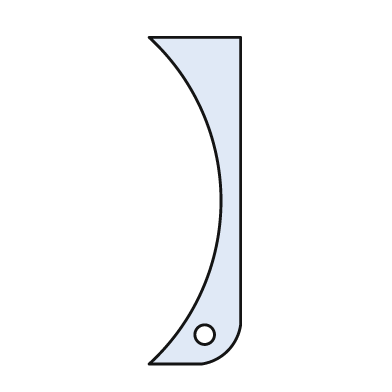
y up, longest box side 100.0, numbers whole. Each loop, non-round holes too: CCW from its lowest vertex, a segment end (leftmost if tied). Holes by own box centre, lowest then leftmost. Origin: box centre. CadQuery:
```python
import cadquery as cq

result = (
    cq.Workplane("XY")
    .moveTo(-14.0, -50.0)
    .lineTo(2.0, -50.0)
    .threePointArc((10.0, -46.0), (14.0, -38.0))
    .lineTo(14.0, 50.0)
    .lineTo(-14.0, 50.0)
    .threePointArc((8.0, 0.0), (-14.0, -50.0))
    .close()
    .moveTo(3.0, -41.0)
    .circle(3.0)
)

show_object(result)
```